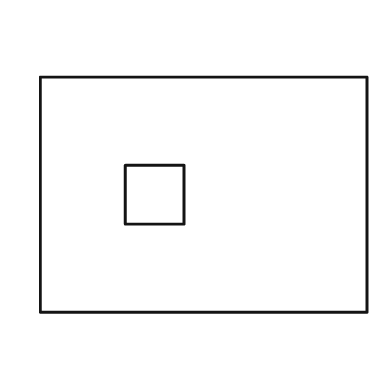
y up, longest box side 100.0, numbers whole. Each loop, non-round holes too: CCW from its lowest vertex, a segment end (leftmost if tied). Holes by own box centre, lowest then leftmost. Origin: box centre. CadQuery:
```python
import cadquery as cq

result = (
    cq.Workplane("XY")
    .moveTo(-50.0, -36.0)
    .lineTo(50.0, -36.0)
    .lineTo(50.0, 36.0)
    .lineTo(-50.0, 36.0)
    .close()
    .moveTo(-24.0, -9.0)
    .lineTo(-6.0, -9.0)
    .lineTo(-6.0, 9.0)
    .lineTo(-24.0, 9.0)
    .close()
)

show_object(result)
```